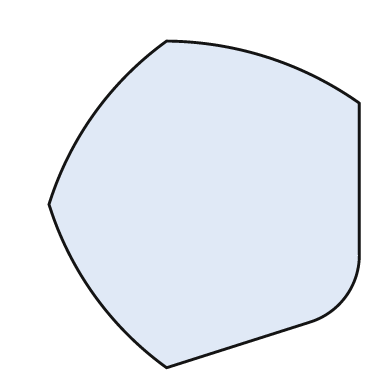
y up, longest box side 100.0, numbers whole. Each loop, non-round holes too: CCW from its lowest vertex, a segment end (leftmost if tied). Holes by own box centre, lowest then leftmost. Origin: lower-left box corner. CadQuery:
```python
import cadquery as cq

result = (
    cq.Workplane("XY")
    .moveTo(36.0, 0.0)
    .lineTo(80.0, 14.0)
    .threePointArc((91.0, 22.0), (95.0, 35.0))
    .lineTo(95.0, 81.0)
    .threePointArc((67.0, 95.0), (36.0, 100.0))
    .threePointArc((14.0, 78.0), (0.0, 50.0))
    .threePointArc((14.0, 22.0), (36.0, 0.0))
    .close()
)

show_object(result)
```